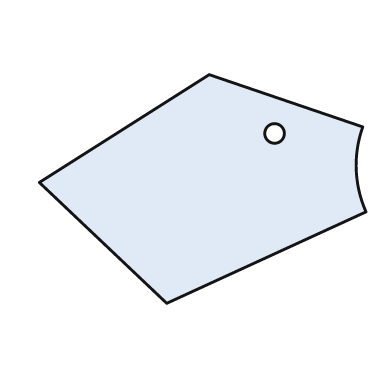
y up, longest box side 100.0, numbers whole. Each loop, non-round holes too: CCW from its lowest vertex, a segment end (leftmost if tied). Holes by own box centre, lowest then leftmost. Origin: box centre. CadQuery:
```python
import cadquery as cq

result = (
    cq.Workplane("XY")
    .moveTo(-11.0, -35.0)
    .lineTo(50.0, -7.0)
    .threePointArc((47.0, 6.0), (49.0, 19.0))
    .lineTo(2.0, 35.0)
    .lineTo(-50.0, 2.0)
    .close()
    .moveTo(22.0, 17.0)
    .circle(3.0)
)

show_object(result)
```